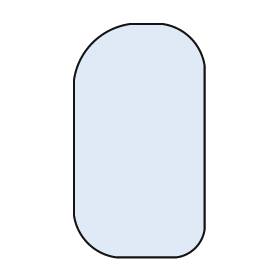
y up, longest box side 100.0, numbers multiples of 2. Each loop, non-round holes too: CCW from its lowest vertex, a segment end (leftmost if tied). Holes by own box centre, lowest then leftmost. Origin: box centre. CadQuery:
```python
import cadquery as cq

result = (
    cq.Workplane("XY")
    .moveTo(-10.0, -50.0)
    .lineTo(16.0, -50.0)
    .threePointArc((24.0, -46.0), (28.0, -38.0))
    .lineTo(28.0, 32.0)
    .threePointArc((22.0, 44.0), (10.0, 50.0))
    .lineTo(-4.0, 50.0)
    .threePointArc((-20.0, 42.0), (-28.0, 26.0))
    .lineTo(-28.0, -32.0)
    .threePointArc((-22.0, -44.0), (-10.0, -50.0))
    .close()
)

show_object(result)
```